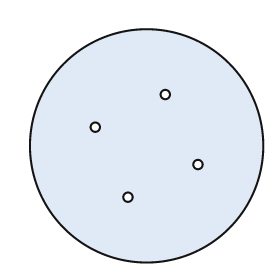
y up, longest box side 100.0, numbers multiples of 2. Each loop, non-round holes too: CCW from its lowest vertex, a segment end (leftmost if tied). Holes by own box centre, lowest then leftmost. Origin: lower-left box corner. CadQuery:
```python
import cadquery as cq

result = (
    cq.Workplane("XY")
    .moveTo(50.0, 50.0)
    .circle(50.0)
    .moveTo(42.0, 28.0)
    .circle(2.0)
    .moveTo(72.0, 42.0)
    .circle(2.0)
    .moveTo(28.0, 58.0)
    .circle(2.0)
    .moveTo(58.0, 72.0)
    .circle(2.0)
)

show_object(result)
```